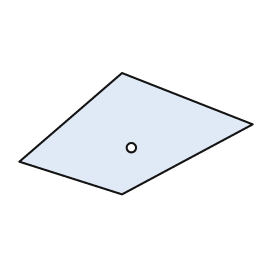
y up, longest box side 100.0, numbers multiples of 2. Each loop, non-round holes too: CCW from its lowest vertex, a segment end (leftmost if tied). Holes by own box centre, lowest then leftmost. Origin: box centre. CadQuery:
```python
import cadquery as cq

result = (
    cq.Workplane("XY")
    .moveTo(-6.0, -26.0)
    .lineTo(50.0, 4.0)
    .lineTo(-6.0, 26.0)
    .lineTo(-50.0, -12.0)
    .close()
    .moveTo(-2.0, -6.0)
    .circle(2.0)
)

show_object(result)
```